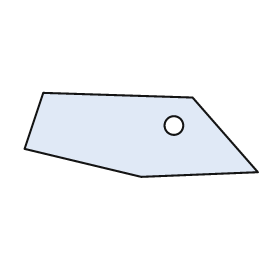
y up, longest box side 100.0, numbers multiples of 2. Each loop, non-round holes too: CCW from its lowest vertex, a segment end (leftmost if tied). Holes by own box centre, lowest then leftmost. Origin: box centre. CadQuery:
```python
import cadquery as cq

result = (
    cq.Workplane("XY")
    .moveTo(0.0, -18.0)
    .lineTo(50.0, -16.0)
    .lineTo(22.0, 16.0)
    .lineTo(-42.0, 18.0)
    .lineTo(-50.0, -6.0)
    .close()
    .moveTo(14.0, 4.0)
    .circle(4.0)
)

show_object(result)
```